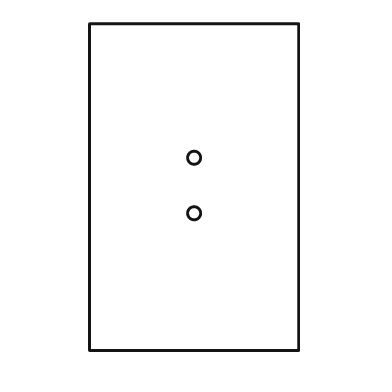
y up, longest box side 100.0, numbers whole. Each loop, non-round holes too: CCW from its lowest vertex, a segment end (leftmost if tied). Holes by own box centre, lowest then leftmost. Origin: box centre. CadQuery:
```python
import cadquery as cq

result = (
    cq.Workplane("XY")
    .moveTo(-32.0, -50.0)
    .lineTo(32.0, -50.0)
    .lineTo(32.0, 50.0)
    .lineTo(-32.0, 50.0)
    .close()
    .moveTo(0.0, -8.0)
    .circle(2.0)
    .moveTo(0.0, 9.0)
    .circle(2.0)
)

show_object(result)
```